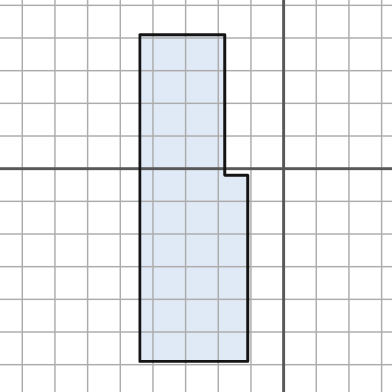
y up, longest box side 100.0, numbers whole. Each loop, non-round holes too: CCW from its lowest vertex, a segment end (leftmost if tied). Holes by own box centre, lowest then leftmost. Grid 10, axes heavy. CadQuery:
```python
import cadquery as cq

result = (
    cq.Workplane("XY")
    .moveTo(-44.0, -59.0)
    .lineTo(-11.0, -59.0)
    .lineTo(-11.0, -2.0)
    .lineTo(-18.0, -2.0)
    .lineTo(-18.0, 41.0)
    .lineTo(-44.0, 41.0)
    .close()
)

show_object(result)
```